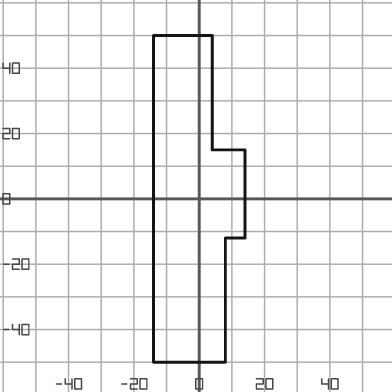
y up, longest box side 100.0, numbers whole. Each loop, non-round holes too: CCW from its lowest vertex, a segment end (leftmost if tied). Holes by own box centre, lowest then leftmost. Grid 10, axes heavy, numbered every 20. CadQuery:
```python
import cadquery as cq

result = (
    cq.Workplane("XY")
    .moveTo(-14.0, -50.0)
    .lineTo(8.0, -50.0)
    .lineTo(8.0, -12.0)
    .lineTo(14.0, -12.0)
    .lineTo(14.0, 15.0)
    .lineTo(4.0, 15.0)
    .lineTo(4.0, 50.0)
    .lineTo(-14.0, 50.0)
    .close()
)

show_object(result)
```